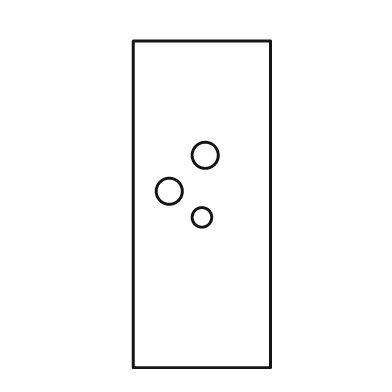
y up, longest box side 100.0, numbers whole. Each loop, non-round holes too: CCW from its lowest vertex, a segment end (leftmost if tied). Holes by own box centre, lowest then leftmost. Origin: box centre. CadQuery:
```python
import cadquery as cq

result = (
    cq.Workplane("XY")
    .moveTo(-21.0, -50.0)
    .lineTo(21.0, -50.0)
    .lineTo(21.0, 50.0)
    .lineTo(-21.0, 50.0)
    .close()
    .moveTo(0.0, -4.0)
    .circle(3.0)
    .moveTo(-10.0, 4.0)
    .circle(4.0)
    .moveTo(1.0, 15.0)
    .circle(4.0)
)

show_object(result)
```